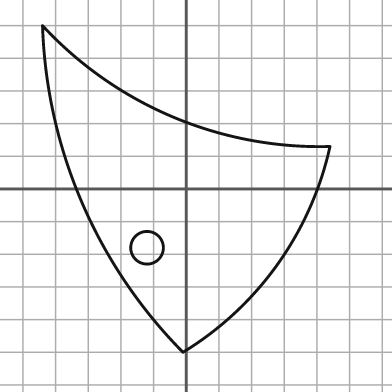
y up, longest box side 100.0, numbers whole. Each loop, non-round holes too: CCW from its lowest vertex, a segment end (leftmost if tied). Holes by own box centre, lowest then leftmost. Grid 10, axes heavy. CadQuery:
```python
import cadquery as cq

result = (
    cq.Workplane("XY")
    .moveTo(-1.0, -50.0)
    .threePointArc((28.0, -23.0), (44.0, 13.0))
    .threePointArc((-4.0, 22.0), (-44.0, 50.0))
    .threePointArc((-32.0, -4.0), (-1.0, -50.0))
    .close()
    .moveTo(-12.0, -18.0)
    .circle(5.0)
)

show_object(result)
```